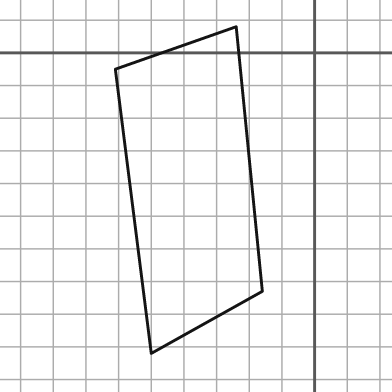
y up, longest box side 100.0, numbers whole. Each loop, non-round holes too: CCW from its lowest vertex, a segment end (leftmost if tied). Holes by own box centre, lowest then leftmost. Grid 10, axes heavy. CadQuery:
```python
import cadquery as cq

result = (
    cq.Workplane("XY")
    .moveTo(-50.0, -92.0)
    .lineTo(-16.0, -73.0)
    .lineTo(-24.0, 8.0)
    .lineTo(-61.0, -5.0)
    .close()
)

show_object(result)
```